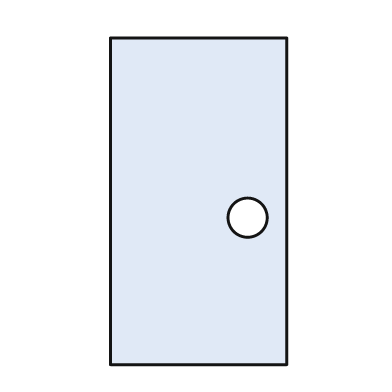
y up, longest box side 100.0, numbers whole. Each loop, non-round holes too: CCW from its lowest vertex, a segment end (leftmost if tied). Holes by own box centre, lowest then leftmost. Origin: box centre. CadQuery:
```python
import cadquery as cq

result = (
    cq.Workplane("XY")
    .moveTo(-27.0, -50.0)
    .lineTo(27.0, -50.0)
    .lineTo(27.0, 50.0)
    .lineTo(-27.0, 50.0)
    .close()
    .moveTo(15.0, -5.0)
    .circle(6.0)
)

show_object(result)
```